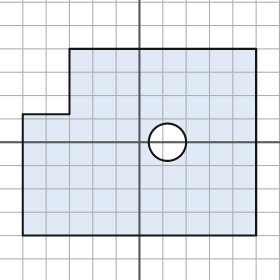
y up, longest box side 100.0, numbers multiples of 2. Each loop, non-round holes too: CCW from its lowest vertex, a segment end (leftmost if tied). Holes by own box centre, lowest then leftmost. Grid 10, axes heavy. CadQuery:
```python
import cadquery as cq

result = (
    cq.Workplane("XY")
    .moveTo(-50.0, -40.0)
    .lineTo(50.0, -40.0)
    .lineTo(50.0, 40.0)
    .lineTo(-30.0, 40.0)
    .lineTo(-30.0, 12.0)
    .lineTo(-50.0, 12.0)
    .close()
    .moveTo(12.0, 0.0)
    .circle(8.0)
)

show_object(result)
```